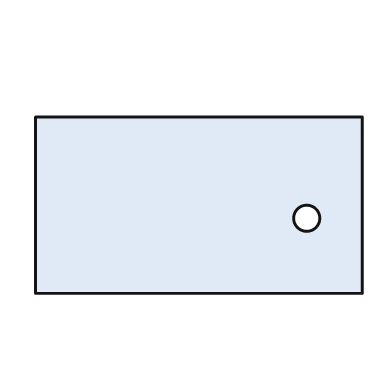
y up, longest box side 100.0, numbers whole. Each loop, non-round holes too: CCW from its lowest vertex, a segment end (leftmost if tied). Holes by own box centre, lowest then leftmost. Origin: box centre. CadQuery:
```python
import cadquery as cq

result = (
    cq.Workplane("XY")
    .moveTo(-50.0, -27.0)
    .lineTo(50.0, -27.0)
    .lineTo(50.0, 27.0)
    .lineTo(-50.0, 27.0)
    .close()
    .moveTo(33.0, -4.0)
    .circle(4.0)
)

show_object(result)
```